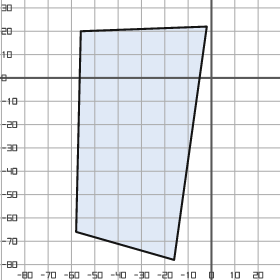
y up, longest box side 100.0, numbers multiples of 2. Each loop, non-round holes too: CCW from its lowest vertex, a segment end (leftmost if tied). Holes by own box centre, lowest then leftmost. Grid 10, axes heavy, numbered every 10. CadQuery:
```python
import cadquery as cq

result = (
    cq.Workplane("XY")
    .moveTo(-16.0, -78.0)
    .lineTo(-2.0, 22.0)
    .lineTo(-56.0, 20.0)
    .lineTo(-58.0, -66.0)
    .close()
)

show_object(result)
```